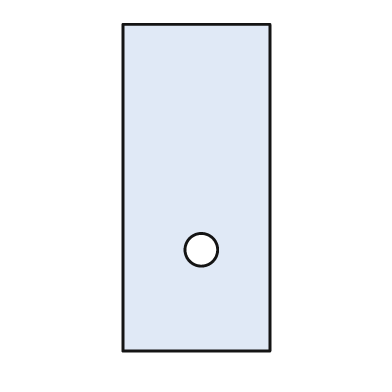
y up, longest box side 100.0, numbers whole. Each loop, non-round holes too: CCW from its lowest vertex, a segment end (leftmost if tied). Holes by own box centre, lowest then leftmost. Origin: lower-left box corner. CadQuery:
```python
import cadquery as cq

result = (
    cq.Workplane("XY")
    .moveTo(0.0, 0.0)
    .lineTo(45.0, 0.0)
    .lineTo(45.0, 100.0)
    .lineTo(0.0, 100.0)
    .close()
    .moveTo(24.0, 31.0)
    .circle(5.0)
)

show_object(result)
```